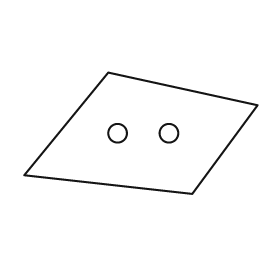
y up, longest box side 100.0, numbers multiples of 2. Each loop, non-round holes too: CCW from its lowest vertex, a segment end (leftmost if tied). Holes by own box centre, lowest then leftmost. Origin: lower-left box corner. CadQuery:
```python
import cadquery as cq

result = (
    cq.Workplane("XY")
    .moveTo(72.0, 0.0)
    .lineTo(100.0, 38.0)
    .lineTo(36.0, 52.0)
    .lineTo(0.0, 8.0)
    .close()
    .moveTo(40.0, 26.0)
    .circle(4.0)
    .moveTo(62.0, 26.0)
    .circle(4.0)
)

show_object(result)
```